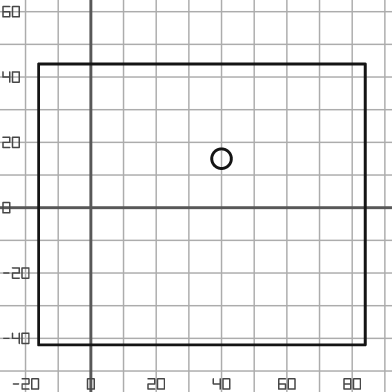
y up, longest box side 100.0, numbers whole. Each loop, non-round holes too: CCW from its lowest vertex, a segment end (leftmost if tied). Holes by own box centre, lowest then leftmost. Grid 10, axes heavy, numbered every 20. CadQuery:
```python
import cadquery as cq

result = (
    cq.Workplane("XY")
    .moveTo(-16.0, -42.0)
    .lineTo(84.0, -42.0)
    .lineTo(84.0, 44.0)
    .lineTo(-16.0, 44.0)
    .close()
    .moveTo(40.0, 15.0)
    .circle(3.0)
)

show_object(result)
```